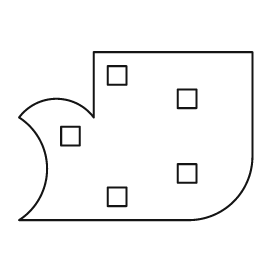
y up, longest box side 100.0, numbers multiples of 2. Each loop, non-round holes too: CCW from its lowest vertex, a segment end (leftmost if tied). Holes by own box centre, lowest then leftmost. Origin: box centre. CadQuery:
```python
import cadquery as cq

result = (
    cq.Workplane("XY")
    .moveTo(-50.0, -36.0)
    .lineTo(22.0, -36.0)
    .threePointArc((42.0, -28.0), (50.0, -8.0))
    .lineTo(50.0, 36.0)
    .lineTo(-18.0, 36.0)
    .lineTo(-18.0, 8.0)
    .threePointArc((-34.0, 16.0), (-50.0, 8.0))
    .threePointArc((-38.0, -14.0), (-50.0, -36.0))
    .close()
    .moveTo(-12.0, -30.0)
    .lineTo(-4.0, -30.0)
    .lineTo(-4.0, -22.0)
    .lineTo(-12.0, -22.0)
    .close()
    .moveTo(18.0, -20.0)
    .lineTo(26.0, -20.0)
    .lineTo(26.0, -12.0)
    .lineTo(18.0, -12.0)
    .close()
    .moveTo(-32.0, -4.0)
    .lineTo(-24.0, -4.0)
    .lineTo(-24.0, 4.0)
    .lineTo(-32.0, 4.0)
    .close()
    .moveTo(18.0, 12.0)
    .lineTo(26.0, 12.0)
    .lineTo(26.0, 20.0)
    .lineTo(18.0, 20.0)
    .close()
    .moveTo(-12.0, 22.0)
    .lineTo(-4.0, 22.0)
    .lineTo(-4.0, 30.0)
    .lineTo(-12.0, 30.0)
    .close()
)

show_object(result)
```